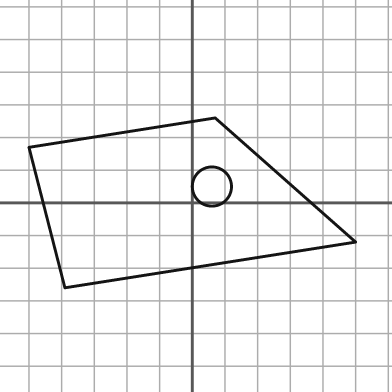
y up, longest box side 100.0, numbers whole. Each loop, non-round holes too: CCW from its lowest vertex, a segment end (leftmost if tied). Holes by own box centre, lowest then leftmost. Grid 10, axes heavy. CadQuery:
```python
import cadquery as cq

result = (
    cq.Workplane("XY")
    .moveTo(-39.0, -26.0)
    .lineTo(50.0, -12.0)
    .lineTo(7.0, 26.0)
    .lineTo(-50.0, 17.0)
    .close()
    .moveTo(6.0, 5.0)
    .circle(6.0)
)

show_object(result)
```